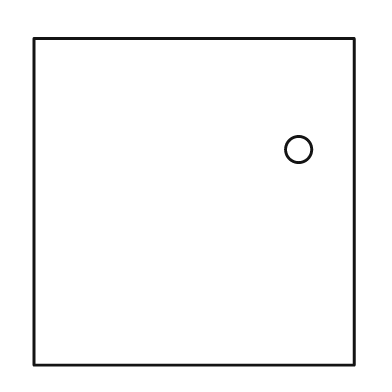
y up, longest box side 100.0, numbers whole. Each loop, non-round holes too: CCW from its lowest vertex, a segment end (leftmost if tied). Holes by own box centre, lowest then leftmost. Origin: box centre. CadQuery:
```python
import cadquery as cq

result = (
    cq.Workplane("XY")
    .moveTo(-49.0, -50.0)
    .lineTo(49.0, -50.0)
    .lineTo(49.0, 50.0)
    .lineTo(-49.0, 50.0)
    .close()
    .moveTo(32.0, 16.0)
    .circle(4.0)
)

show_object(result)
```